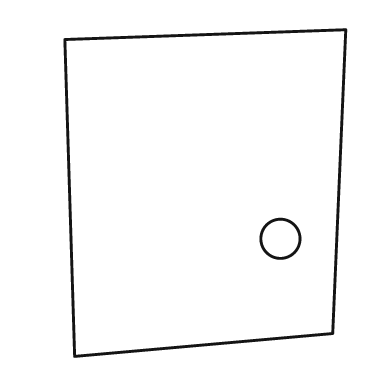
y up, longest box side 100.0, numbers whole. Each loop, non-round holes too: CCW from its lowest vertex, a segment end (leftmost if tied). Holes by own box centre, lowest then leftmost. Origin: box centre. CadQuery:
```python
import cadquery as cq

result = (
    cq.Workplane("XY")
    .moveTo(-40.0, -50.0)
    .lineTo(39.0, -43.0)
    .lineTo(43.0, 50.0)
    .lineTo(-43.0, 47.0)
    .close()
    .moveTo(23.0, -14.0)
    .circle(6.0)
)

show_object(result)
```